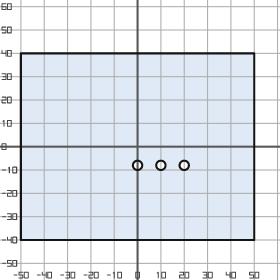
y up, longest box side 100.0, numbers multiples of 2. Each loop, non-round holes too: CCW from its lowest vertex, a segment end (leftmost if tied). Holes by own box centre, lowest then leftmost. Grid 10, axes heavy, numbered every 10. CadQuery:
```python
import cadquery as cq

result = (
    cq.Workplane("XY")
    .moveTo(-50.0, -40.0)
    .lineTo(50.0, -40.0)
    .lineTo(50.0, 40.0)
    .lineTo(-50.0, 40.0)
    .close()
    .moveTo(0.0, -8.0)
    .circle(2.0)
    .moveTo(10.0, -8.0)
    .circle(2.0)
    .moveTo(20.0, -8.0)
    .circle(2.0)
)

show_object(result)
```